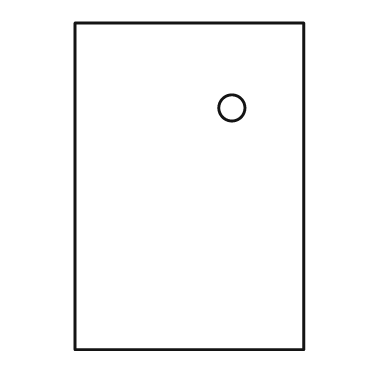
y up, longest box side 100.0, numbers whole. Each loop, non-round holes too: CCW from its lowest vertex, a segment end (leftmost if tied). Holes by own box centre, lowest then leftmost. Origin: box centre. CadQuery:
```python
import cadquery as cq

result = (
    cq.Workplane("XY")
    .moveTo(-35.0, -50.0)
    .lineTo(35.0, -50.0)
    .lineTo(35.0, 50.0)
    .lineTo(-35.0, 50.0)
    .close()
    .moveTo(13.0, 24.0)
    .circle(4.0)
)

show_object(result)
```